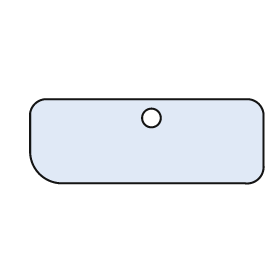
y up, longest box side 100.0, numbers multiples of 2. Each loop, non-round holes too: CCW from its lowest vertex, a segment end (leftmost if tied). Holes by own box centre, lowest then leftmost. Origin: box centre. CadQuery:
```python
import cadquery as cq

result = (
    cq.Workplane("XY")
    .moveTo(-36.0, -18.0)
    .lineTo(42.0, -18.0)
    .threePointArc((48.0, -16.0), (50.0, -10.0))
    .lineTo(50.0, 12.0)
    .threePointArc((48.0, 16.0), (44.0, 18.0))
    .lineTo(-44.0, 18.0)
    .threePointArc((-48.0, 16.0), (-50.0, 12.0))
    .lineTo(-50.0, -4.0)
    .threePointArc((-46.0, -14.0), (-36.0, -18.0))
    .close()
    .moveTo(2.0, 10.0)
    .circle(4.0)
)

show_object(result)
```